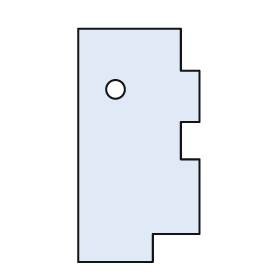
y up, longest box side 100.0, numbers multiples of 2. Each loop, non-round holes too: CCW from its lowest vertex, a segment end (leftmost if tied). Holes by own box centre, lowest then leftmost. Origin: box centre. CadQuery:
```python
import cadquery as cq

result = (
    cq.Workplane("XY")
    .moveTo(-26.0, -50.0)
    .lineTo(6.0, -50.0)
    .lineTo(6.0, -38.0)
    .lineTo(26.0, -38.0)
    .lineTo(26.0, -6.0)
    .lineTo(18.0, -6.0)
    .lineTo(18.0, 10.0)
    .lineTo(26.0, 10.0)
    .lineTo(26.0, 32.0)
    .lineTo(18.0, 32.0)
    .lineTo(18.0, 50.0)
    .lineTo(-26.0, 50.0)
    .close()
    .moveTo(-10.0, 24.0)
    .circle(4.0)
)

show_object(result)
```